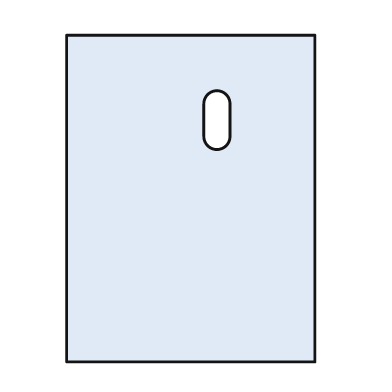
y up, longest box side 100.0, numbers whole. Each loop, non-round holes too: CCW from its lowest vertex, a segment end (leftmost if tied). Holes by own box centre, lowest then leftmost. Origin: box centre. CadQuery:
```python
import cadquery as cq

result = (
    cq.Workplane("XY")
    .moveTo(-38.0, -50.0)
    .lineTo(38.0, -50.0)
    .lineTo(38.0, 50.0)
    .lineTo(-38.0, 50.0)
    .close()
    .moveTo(4.0, 19.0)
    .threePointArc((8.0, 15.0), (12.0, 19.0))
    .lineTo(12.0, 29.0)
    .threePointArc((8.0, 33.0), (4.0, 29.0))
    .close()
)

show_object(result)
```